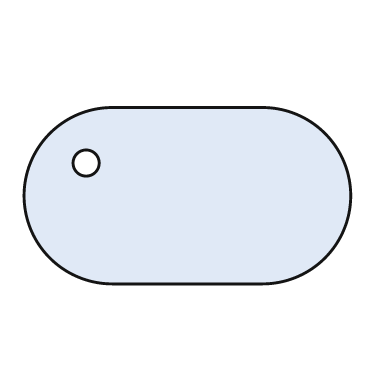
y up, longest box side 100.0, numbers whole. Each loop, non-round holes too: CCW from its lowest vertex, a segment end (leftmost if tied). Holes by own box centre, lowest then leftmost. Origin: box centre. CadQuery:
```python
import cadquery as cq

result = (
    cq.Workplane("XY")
    .moveTo(-23.0, -27.0)
    .lineTo(23.0, -27.0)
    .threePointArc((50.0, 0.0), (23.0, 27.0))
    .lineTo(-23.0, 27.0)
    .threePointArc((-50.0, 0.0), (-23.0, -27.0))
    .close()
    .moveTo(-31.0, 10.0)
    .circle(4.0)
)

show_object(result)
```